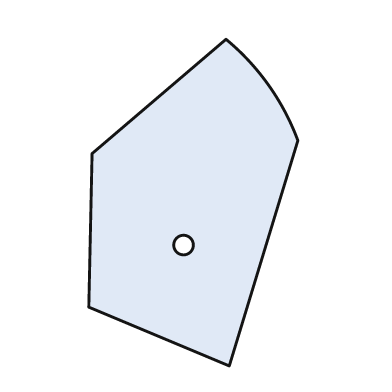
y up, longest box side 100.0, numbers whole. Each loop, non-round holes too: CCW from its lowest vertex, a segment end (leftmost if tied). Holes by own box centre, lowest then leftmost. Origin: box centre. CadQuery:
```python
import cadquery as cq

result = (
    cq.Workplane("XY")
    .moveTo(11.0, -50.0)
    .lineTo(32.0, 19.0)
    .threePointArc((23.0, 36.0), (10.0, 50.0))
    .lineTo(-31.0, 15.0)
    .lineTo(-32.0, -32.0)
    .close()
    .moveTo(-3.0, -13.0)
    .circle(3.0)
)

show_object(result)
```